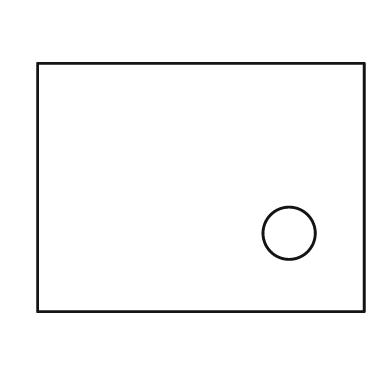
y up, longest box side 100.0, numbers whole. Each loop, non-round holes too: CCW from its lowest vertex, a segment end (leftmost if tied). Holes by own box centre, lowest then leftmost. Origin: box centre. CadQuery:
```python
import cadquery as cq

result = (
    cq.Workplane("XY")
    .moveTo(-50.0, -38.0)
    .lineTo(50.0, -38.0)
    .lineTo(50.0, 38.0)
    .lineTo(-50.0, 38.0)
    .close()
    .moveTo(27.0, -14.0)
    .circle(8.0)
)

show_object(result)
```